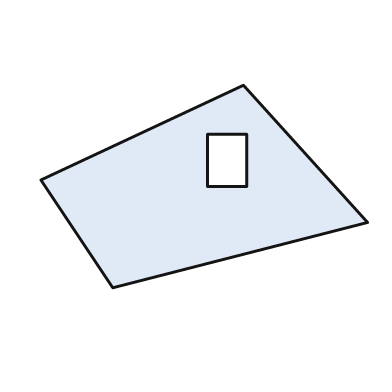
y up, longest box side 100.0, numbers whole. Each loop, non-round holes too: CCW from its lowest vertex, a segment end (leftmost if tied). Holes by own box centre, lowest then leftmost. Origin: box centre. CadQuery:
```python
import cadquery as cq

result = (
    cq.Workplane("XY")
    .moveTo(-28.0, -31.0)
    .lineTo(50.0, -11.0)
    .lineTo(12.0, 31.0)
    .lineTo(-50.0, 2.0)
    .close()
    .moveTo(1.0, 0.0)
    .lineTo(13.0, 0.0)
    .lineTo(13.0, 16.0)
    .lineTo(1.0, 16.0)
    .close()
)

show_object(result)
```